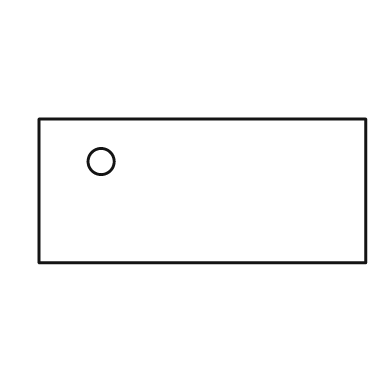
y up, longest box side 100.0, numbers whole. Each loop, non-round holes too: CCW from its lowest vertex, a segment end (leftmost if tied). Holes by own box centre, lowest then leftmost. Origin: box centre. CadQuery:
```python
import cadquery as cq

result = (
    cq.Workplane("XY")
    .moveTo(-50.0, -22.0)
    .lineTo(50.0, -22.0)
    .lineTo(50.0, 22.0)
    .lineTo(-50.0, 22.0)
    .close()
    .moveTo(-31.0, 9.0)
    .circle(4.0)
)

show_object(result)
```